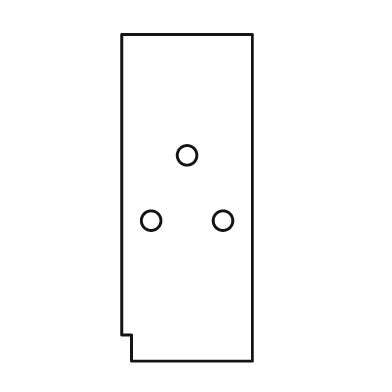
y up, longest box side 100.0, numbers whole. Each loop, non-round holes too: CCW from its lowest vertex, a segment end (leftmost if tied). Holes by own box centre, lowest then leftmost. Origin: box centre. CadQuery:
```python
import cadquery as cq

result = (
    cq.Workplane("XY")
    .moveTo(-17.0, -50.0)
    .lineTo(20.0, -50.0)
    .lineTo(20.0, 50.0)
    .lineTo(-20.0, 50.0)
    .lineTo(-20.0, -42.0)
    .lineTo(-17.0, -42.0)
    .close()
    .moveTo(-11.0, -7.0)
    .circle(3.0)
    .moveTo(11.0, -7.0)
    .circle(3.0)
    .moveTo(0.0, 13.0)
    .circle(3.0)
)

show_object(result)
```